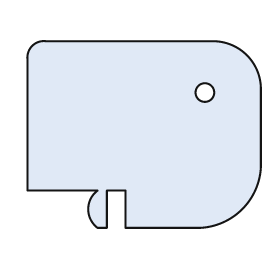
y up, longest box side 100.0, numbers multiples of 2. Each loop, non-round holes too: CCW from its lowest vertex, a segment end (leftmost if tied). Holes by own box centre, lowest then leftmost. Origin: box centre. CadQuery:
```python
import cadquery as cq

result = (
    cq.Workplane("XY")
    .moveTo(-20.0, -40.0)
    .lineTo(-16.0, -40.0)
    .lineTo(-16.0, -24.0)
    .lineTo(-8.0, -24.0)
    .lineTo(-8.0, -40.0)
    .lineTo(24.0, -40.0)
    .threePointArc((42.0, -32.0), (50.0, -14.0))
    .lineTo(50.0, 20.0)
    .threePointArc((44.0, 34.0), (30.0, 40.0))
    .lineTo(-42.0, 40.0)
    .threePointArc((-48.0, 38.0), (-50.0, 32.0))
    .lineTo(-50.0, -24.0)
    .lineTo(-20.0, -24.0)
    .threePointArc((-24.0, -32.0), (-20.0, -40.0))
    .close()
    .moveTo(26.0, 18.0)
    .circle(4.0)
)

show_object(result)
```